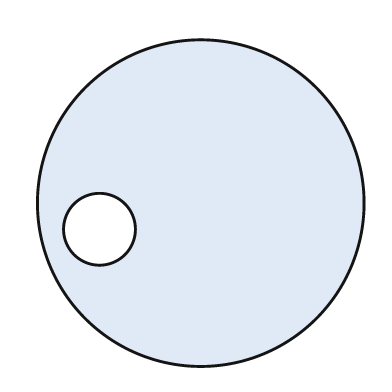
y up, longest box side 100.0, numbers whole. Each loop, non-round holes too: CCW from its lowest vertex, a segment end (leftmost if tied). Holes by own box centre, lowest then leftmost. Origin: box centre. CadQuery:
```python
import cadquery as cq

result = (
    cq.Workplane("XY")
    .moveTo(0.0, 0.0)
    .circle(50.0)
    .moveTo(-31.0, -8.0)
    .circle(11.0)
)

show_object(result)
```